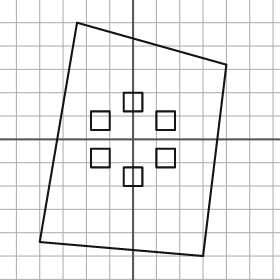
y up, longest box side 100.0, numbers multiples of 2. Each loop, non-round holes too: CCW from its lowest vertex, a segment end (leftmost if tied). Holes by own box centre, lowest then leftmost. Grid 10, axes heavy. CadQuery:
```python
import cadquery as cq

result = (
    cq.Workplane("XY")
    .moveTo(30.0, -50.0)
    .lineTo(40.0, 32.0)
    .lineTo(-24.0, 50.0)
    .lineTo(-40.0, -44.0)
    .close()
    .moveTo(-4.0, -20.0)
    .lineTo(4.0, -20.0)
    .lineTo(4.0, -12.0)
    .lineTo(-4.0, -12.0)
    .close()
    .moveTo(-18.0, -12.0)
    .lineTo(-10.0, -12.0)
    .lineTo(-10.0, -4.0)
    .lineTo(-18.0, -4.0)
    .close()
    .moveTo(10.0, -12.0)
    .lineTo(18.0, -12.0)
    .lineTo(18.0, -4.0)
    .lineTo(10.0, -4.0)
    .close()
    .moveTo(-18.0, 4.0)
    .lineTo(-10.0, 4.0)
    .lineTo(-10.0, 12.0)
    .lineTo(-18.0, 12.0)
    .close()
    .moveTo(10.0, 4.0)
    .lineTo(18.0, 4.0)
    .lineTo(18.0, 12.0)
    .lineTo(10.0, 12.0)
    .close()
    .moveTo(-4.0, 12.0)
    .lineTo(4.0, 12.0)
    .lineTo(4.0, 20.0)
    .lineTo(-4.0, 20.0)
    .close()
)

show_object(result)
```